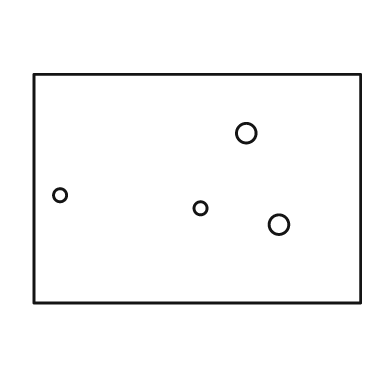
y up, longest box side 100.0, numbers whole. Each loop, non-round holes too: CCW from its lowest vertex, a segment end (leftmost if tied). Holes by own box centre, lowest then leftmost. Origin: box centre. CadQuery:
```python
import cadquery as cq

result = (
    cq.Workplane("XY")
    .moveTo(-50.0, -35.0)
    .lineTo(50.0, -35.0)
    .lineTo(50.0, 35.0)
    .lineTo(-50.0, 35.0)
    .close()
    .moveTo(25.0, -11.0)
    .circle(3.0)
    .moveTo(1.0, -6.0)
    .circle(2.0)
    .moveTo(-42.0, -2.0)
    .circle(2.0)
    .moveTo(15.0, 17.0)
    .circle(3.0)
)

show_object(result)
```